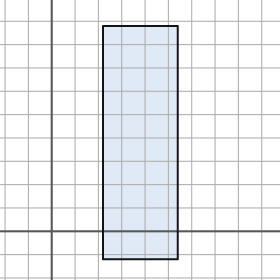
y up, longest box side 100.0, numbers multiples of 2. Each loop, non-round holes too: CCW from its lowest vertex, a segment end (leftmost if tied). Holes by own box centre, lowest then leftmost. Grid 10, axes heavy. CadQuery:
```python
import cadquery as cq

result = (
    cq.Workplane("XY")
    .moveTo(22.0, -12.0)
    .lineTo(54.0, -12.0)
    .lineTo(54.0, 88.0)
    .lineTo(22.0, 88.0)
    .close()
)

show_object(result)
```